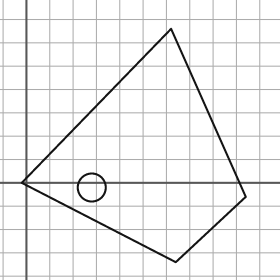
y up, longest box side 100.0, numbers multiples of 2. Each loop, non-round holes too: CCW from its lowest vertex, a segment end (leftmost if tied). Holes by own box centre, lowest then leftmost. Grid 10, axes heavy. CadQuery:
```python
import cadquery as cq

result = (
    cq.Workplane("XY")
    .moveTo(64.0, -34.0)
    .lineTo(94.0, -6.0)
    .lineTo(62.0, 66.0)
    .lineTo(-2.0, 0.0)
    .close()
    .moveTo(28.0, -2.0)
    .circle(6.0)
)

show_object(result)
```